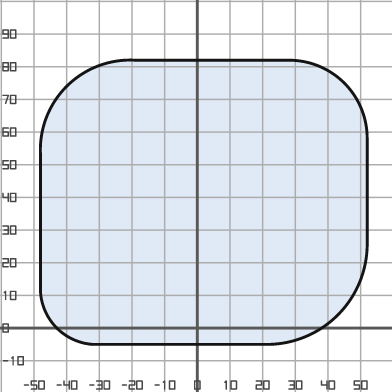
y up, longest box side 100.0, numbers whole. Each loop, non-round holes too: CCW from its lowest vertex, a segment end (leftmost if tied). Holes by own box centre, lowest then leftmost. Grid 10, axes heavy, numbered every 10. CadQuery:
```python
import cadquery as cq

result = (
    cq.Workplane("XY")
    .moveTo(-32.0, -5.0)
    .lineTo(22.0, -5.0)
    .threePointArc((43.0, 4.0), (52.0, 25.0))
    .lineTo(52.0, 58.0)
    .threePointArc((45.0, 75.0), (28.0, 82.0))
    .lineTo(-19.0, 82.0)
    .threePointArc((-40.0, 74.0), (-48.0, 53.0))
    .lineTo(-48.0, 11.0)
    .threePointArc((-43.0, 0.0), (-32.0, -5.0))
    .close()
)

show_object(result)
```